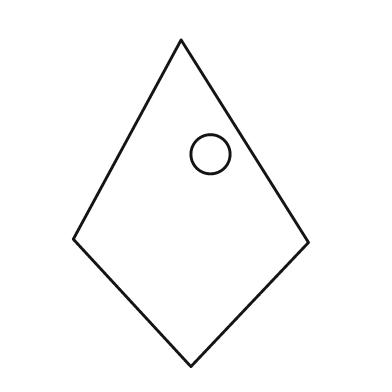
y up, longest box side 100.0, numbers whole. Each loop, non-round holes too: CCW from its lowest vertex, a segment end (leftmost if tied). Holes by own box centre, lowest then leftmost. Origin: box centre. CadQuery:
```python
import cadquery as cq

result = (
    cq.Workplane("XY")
    .moveTo(0.0, -50.0)
    .lineTo(36.0, -12.0)
    .lineTo(-3.0, 50.0)
    .lineTo(-36.0, -11.0)
    .close()
    .moveTo(6.0, 15.0)
    .circle(6.0)
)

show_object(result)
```